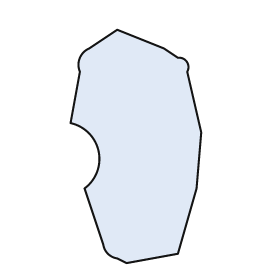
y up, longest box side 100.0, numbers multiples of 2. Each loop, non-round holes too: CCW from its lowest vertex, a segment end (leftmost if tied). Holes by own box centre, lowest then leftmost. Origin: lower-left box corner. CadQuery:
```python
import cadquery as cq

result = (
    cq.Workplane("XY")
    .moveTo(24.0, 0.0)
    .lineTo(46.0, 4.0)
    .lineTo(54.0, 32.0)
    .lineTo(56.0, 56.0)
    .lineTo(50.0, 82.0)
    .threePointArc((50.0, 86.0), (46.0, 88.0))
    .lineTo(40.0, 92.0)
    .lineTo(20.0, 100.0)
    .lineTo(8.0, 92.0)
    .threePointArc((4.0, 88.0), (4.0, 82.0))
    .lineTo(0.0, 60.0)
    .threePointArc((12.0, 48.0), (6.0, 32.0))
    .lineTo(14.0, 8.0)
    .threePointArc((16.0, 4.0), (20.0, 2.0))
    .close()
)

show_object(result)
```